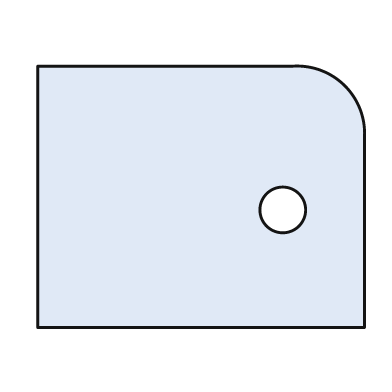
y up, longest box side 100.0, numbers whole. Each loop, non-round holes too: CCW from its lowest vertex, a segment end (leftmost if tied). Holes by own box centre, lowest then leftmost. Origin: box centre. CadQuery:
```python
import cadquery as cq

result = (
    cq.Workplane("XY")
    .moveTo(-50.0, -40.0)
    .lineTo(50.0, -40.0)
    .lineTo(50.0, 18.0)
    .threePointArc((44.0, 34.0), (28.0, 40.0))
    .lineTo(-50.0, 40.0)
    .close()
    .moveTo(25.0, -4.0)
    .circle(7.0)
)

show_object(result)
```